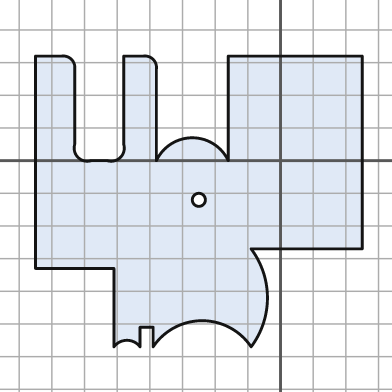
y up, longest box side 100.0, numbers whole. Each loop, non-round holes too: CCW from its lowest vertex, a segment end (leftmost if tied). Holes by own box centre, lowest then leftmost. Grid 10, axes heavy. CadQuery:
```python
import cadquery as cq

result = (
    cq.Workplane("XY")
    .moveTo(-51.0, -57.0)
    .threePointArc((-47.0, -55.0), (-43.0, -57.0))
    .lineTo(-43.0, -51.0)
    .lineTo(-39.0, -51.0)
    .lineTo(-39.0, -57.0)
    .threePointArc((-24.0, -49.0), (-9.0, -57.0))
    .threePointArc((-4.0, -42.0), (-9.0, -27.0))
    .lineTo(25.0, -27.0)
    .lineTo(25.0, 32.0)
    .lineTo(-16.0, 32.0)
    .lineTo(-16.0, 0.0)
    .threePointArc((-27.0, 7.0), (-38.0, 0.0))
    .lineTo(-38.0, 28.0)
    .threePointArc((-39.0, 31.0), (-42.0, 32.0))
    .lineTo(-48.0, 32.0)
    .lineTo(-48.0, 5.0)
    .threePointArc((-49.0, 1.0), (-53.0, 0.0))
    .lineTo(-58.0, 0.0)
    .threePointArc((-62.0, 1.0), (-63.0, 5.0))
    .lineTo(-63.0, 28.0)
    .threePointArc((-64.0, 31.0), (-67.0, 32.0))
    .lineTo(-75.0, 32.0)
    .lineTo(-75.0, -33.0)
    .lineTo(-51.0, -33.0)
    .close()
    .moveTo(-25.0, -12.0)
    .circle(2.0)
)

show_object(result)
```